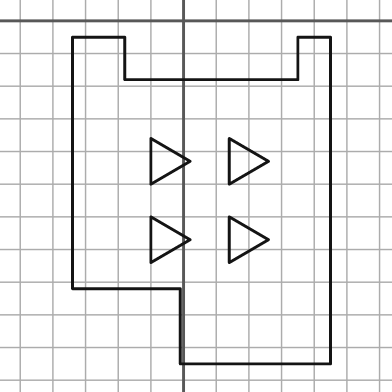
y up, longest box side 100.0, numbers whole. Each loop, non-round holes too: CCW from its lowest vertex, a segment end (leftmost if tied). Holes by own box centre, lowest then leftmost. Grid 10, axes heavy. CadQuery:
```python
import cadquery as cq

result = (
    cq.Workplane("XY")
    .moveTo(-1.0, -105.0)
    .lineTo(45.0, -105.0)
    .lineTo(45.0, -5.0)
    .lineTo(35.0, -5.0)
    .lineTo(35.0, -18.0)
    .lineTo(-18.0, -18.0)
    .lineTo(-18.0, -5.0)
    .lineTo(-34.0, -5.0)
    .lineTo(-34.0, -82.0)
    .lineTo(-1.0, -82.0)
    .close()
    .moveTo(-10.0, -74.0)
    .lineTo(2.0, -67.0)
    .lineTo(-10.0, -60.0)
    .close()
    .moveTo(14.0, -74.0)
    .lineTo(26.0, -67.0)
    .lineTo(14.0, -60.0)
    .close()
    .moveTo(-10.0, -50.0)
    .lineTo(2.0, -43.0)
    .lineTo(-10.0, -36.0)
    .close()
    .moveTo(14.0, -50.0)
    .lineTo(26.0, -43.0)
    .lineTo(14.0, -36.0)
    .close()
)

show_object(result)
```